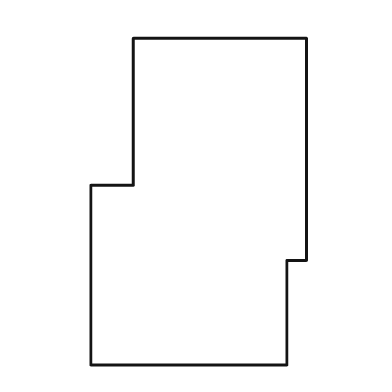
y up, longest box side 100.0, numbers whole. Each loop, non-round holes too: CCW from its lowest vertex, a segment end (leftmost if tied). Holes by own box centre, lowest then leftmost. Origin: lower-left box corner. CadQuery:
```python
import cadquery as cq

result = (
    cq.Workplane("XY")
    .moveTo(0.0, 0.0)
    .lineTo(60.0, 0.0)
    .lineTo(60.0, 32.0)
    .lineTo(66.0, 32.0)
    .lineTo(66.0, 100.0)
    .lineTo(13.0, 100.0)
    .lineTo(13.0, 55.0)
    .lineTo(0.0, 55.0)
    .close()
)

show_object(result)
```